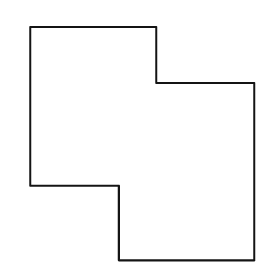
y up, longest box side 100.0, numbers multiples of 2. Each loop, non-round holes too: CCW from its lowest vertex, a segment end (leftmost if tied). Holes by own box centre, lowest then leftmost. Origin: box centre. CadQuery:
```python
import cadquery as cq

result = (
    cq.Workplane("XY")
    .moveTo(-10.0, -50.0)
    .lineTo(48.0, -50.0)
    .lineTo(48.0, 26.0)
    .lineTo(6.0, 26.0)
    .lineTo(6.0, 50.0)
    .lineTo(-48.0, 50.0)
    .lineTo(-48.0, -18.0)
    .lineTo(-10.0, -18.0)
    .close()
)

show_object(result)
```